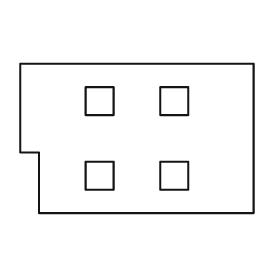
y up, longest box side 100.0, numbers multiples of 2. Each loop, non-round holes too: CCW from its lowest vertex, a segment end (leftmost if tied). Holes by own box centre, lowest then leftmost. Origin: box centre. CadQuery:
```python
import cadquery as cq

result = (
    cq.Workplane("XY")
    .moveTo(-42.0, -32.0)
    .lineTo(50.0, -32.0)
    .lineTo(50.0, 32.0)
    .lineTo(-50.0, 32.0)
    .lineTo(-50.0, -6.0)
    .lineTo(-42.0, -6.0)
    .close()
    .moveTo(-22.0, -22.0)
    .lineTo(-10.0, -22.0)
    .lineTo(-10.0, -10.0)
    .lineTo(-22.0, -10.0)
    .close()
    .moveTo(10.0, -22.0)
    .lineTo(22.0, -22.0)
    .lineTo(22.0, -10.0)
    .lineTo(10.0, -10.0)
    .close()
    .moveTo(-22.0, 10.0)
    .lineTo(-10.0, 10.0)
    .lineTo(-10.0, 22.0)
    .lineTo(-22.0, 22.0)
    .close()
    .moveTo(10.0, 10.0)
    .lineTo(22.0, 10.0)
    .lineTo(22.0, 22.0)
    .lineTo(10.0, 22.0)
    .close()
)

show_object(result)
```